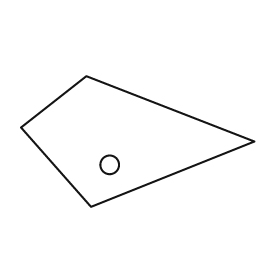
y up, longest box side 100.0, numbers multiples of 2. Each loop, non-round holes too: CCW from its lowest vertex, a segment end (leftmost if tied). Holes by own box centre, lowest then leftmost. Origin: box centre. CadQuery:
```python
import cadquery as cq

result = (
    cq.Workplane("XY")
    .moveTo(-20.0, -28.0)
    .lineTo(50.0, 0.0)
    .lineTo(-22.0, 28.0)
    .lineTo(-50.0, 6.0)
    .close()
    .moveTo(-12.0, -10.0)
    .circle(4.0)
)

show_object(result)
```